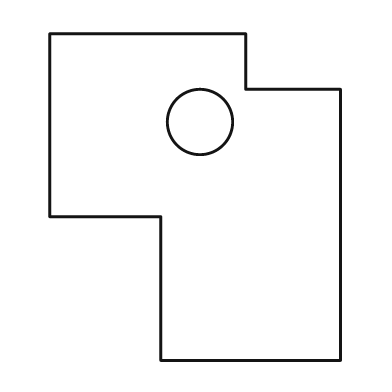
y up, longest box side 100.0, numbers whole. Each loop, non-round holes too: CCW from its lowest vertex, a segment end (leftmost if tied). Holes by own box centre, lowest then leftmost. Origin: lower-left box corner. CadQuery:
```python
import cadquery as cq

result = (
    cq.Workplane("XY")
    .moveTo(34.0, 0.0)
    .lineTo(89.0, 0.0)
    .lineTo(89.0, 83.0)
    .lineTo(60.0, 83.0)
    .lineTo(60.0, 100.0)
    .lineTo(0.0, 100.0)
    .lineTo(0.0, 44.0)
    .lineTo(34.0, 44.0)
    .close()
    .moveTo(46.0, 73.0)
    .circle(10.0)
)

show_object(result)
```